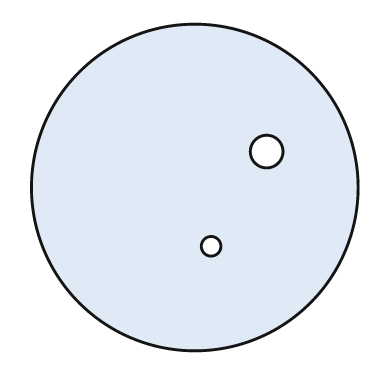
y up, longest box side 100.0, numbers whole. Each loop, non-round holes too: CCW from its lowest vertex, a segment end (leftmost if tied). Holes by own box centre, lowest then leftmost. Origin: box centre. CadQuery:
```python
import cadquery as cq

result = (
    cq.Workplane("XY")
    .moveTo(0.0, 0.0)
    .circle(50.0)
    .moveTo(5.0, -18.0)
    .circle(3.0)
    .moveTo(22.0, 11.0)
    .circle(5.0)
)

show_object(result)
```